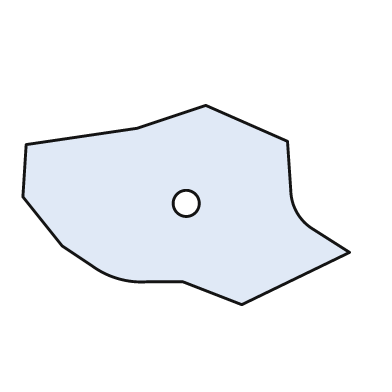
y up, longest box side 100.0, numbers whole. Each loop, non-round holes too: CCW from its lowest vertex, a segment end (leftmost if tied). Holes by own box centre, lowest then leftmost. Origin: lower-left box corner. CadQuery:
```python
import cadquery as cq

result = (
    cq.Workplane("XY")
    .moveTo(67.0, 0.0)
    .lineTo(100.0, 16.0)
    .lineTo(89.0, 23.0)
    .threePointArc((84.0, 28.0), (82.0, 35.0))
    .lineTo(81.0, 50.0)
    .lineTo(56.0, 61.0)
    .lineTo(35.0, 54.0)
    .lineTo(1.0, 49.0)
    .lineTo(0.0, 33.0)
    .lineTo(12.0, 18.0)
    .lineTo(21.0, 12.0)
    .threePointArc((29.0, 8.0), (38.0, 7.0))
    .lineTo(49.0, 7.0)
    .close()
    .moveTo(50.0, 31.0)
    .circle(4.0)
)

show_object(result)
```